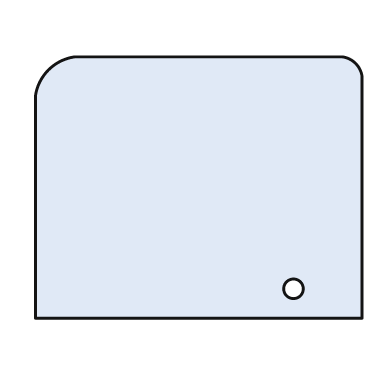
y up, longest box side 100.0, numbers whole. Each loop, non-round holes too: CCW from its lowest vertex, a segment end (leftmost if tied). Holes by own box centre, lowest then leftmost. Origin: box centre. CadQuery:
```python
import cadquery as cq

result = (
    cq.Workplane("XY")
    .moveTo(-50.0, -40.0)
    .lineTo(50.0, -40.0)
    .lineTo(50.0, 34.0)
    .threePointArc((48.0, 38.0), (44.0, 40.0))
    .lineTo(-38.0, 40.0)
    .threePointArc((-46.0, 36.0), (-50.0, 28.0))
    .close()
    .moveTo(29.0, -31.0)
    .circle(3.0)
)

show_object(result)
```